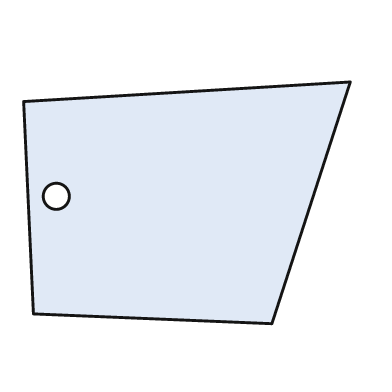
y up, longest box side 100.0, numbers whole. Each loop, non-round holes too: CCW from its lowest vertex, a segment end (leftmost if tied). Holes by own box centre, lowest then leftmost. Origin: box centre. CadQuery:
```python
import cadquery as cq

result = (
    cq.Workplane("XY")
    .moveTo(26.0, -37.0)
    .lineTo(50.0, 37.0)
    .lineTo(-50.0, 31.0)
    .lineTo(-47.0, -34.0)
    .close()
    .moveTo(-40.0, 2.0)
    .circle(4.0)
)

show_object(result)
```